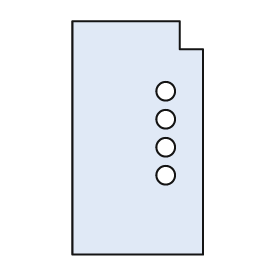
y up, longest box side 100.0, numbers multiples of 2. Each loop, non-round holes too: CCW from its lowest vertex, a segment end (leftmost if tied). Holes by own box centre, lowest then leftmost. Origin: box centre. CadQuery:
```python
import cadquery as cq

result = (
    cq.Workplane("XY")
    .moveTo(-28.0, -50.0)
    .lineTo(28.0, -50.0)
    .lineTo(28.0, 38.0)
    .lineTo(18.0, 38.0)
    .lineTo(18.0, 50.0)
    .lineTo(-28.0, 50.0)
    .close()
    .moveTo(12.0, -16.0)
    .circle(4.0)
    .moveTo(12.0, -4.0)
    .circle(4.0)
    .moveTo(12.0, 8.0)
    .circle(4.0)
    .moveTo(12.0, 20.0)
    .circle(4.0)
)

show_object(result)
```